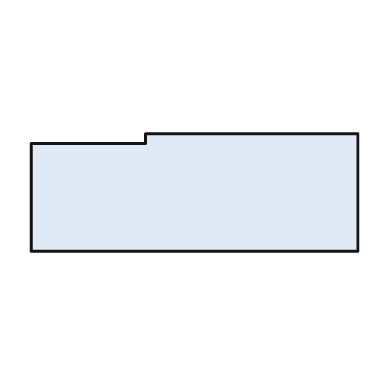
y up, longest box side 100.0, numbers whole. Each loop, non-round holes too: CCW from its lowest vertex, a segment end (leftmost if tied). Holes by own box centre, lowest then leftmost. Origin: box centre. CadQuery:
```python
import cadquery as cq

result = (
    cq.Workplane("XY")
    .moveTo(-50.0, -18.0)
    .lineTo(50.0, -18.0)
    .lineTo(50.0, 18.0)
    .lineTo(-15.0, 18.0)
    .lineTo(-15.0, 15.0)
    .lineTo(-50.0, 15.0)
    .close()
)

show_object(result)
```